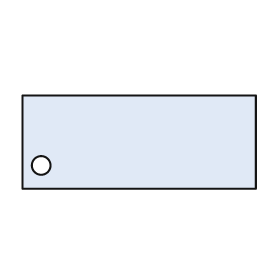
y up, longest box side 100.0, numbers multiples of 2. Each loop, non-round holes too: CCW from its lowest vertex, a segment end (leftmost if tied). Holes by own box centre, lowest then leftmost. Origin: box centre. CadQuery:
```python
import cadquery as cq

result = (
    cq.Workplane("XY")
    .moveTo(-50.0, -20.0)
    .lineTo(50.0, -20.0)
    .lineTo(50.0, 20.0)
    .lineTo(-50.0, 20.0)
    .close()
    .moveTo(-42.0, -10.0)
    .circle(4.0)
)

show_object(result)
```